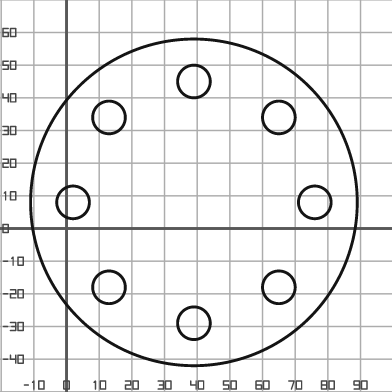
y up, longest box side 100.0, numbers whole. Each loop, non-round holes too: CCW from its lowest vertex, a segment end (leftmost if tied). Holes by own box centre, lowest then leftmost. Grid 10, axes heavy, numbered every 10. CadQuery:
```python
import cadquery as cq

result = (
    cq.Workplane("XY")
    .moveTo(39.0, 8.0)
    .circle(50.0)
    .moveTo(39.0, -29.0)
    .circle(5.0)
    .moveTo(13.0, -18.0)
    .circle(5.0)
    .moveTo(65.0, -18.0)
    .circle(5.0)
    .moveTo(2.0, 8.0)
    .circle(5.0)
    .moveTo(76.0, 8.0)
    .circle(5.0)
    .moveTo(13.0, 34.0)
    .circle(5.0)
    .moveTo(65.0, 34.0)
    .circle(5.0)
    .moveTo(39.0, 45.0)
    .circle(5.0)
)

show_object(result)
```